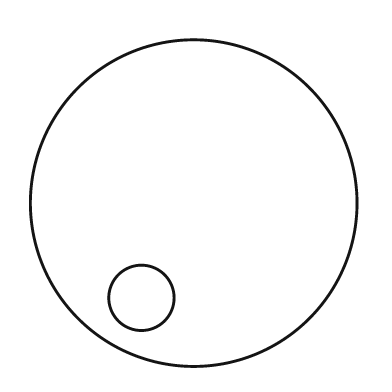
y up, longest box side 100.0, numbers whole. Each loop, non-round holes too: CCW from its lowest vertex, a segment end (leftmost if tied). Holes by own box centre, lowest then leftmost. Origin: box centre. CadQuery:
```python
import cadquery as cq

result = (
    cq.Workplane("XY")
    .moveTo(0.0, 0.0)
    .circle(50.0)
    .moveTo(-16.0, -29.0)
    .circle(10.0)
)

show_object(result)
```